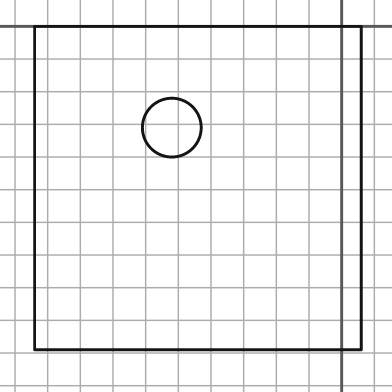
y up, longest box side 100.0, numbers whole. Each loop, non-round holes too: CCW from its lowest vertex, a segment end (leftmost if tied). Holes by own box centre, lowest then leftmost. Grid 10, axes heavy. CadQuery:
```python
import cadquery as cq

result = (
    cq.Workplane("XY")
    .moveTo(-94.0, -99.0)
    .lineTo(6.0, -99.0)
    .lineTo(6.0, 0.0)
    .lineTo(-94.0, 0.0)
    .close()
    .moveTo(-52.0, -31.0)
    .circle(9.0)
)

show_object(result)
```